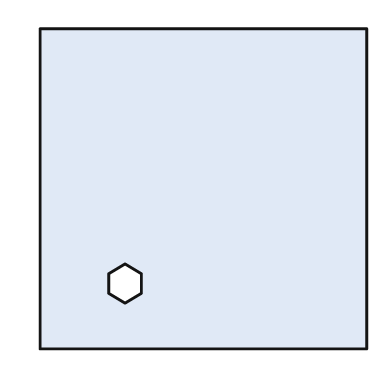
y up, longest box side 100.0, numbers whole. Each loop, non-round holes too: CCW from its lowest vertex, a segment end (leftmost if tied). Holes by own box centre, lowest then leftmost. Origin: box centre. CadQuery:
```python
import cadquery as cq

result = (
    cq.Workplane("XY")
    .moveTo(-50.0, -49.0)
    .lineTo(50.0, -49.0)
    .lineTo(50.0, 49.0)
    .lineTo(-50.0, 49.0)
    .close()
    .moveTo(-24.0, -35.0)
    .lineTo(-19.0, -32.0)
    .lineTo(-19.0, -26.0)
    .lineTo(-24.0, -23.0)
    .lineTo(-29.0, -26.0)
    .lineTo(-29.0, -32.0)
    .close()
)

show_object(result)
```